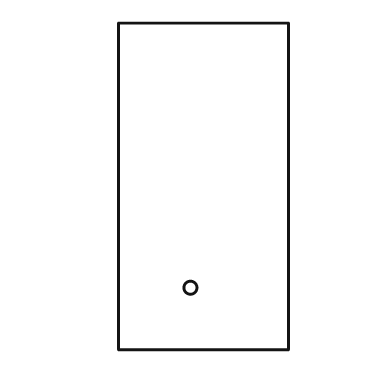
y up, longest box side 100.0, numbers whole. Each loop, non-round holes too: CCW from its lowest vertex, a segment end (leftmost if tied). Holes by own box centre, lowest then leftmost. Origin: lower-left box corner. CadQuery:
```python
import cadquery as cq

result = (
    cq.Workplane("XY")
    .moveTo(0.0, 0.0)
    .lineTo(52.0, 0.0)
    .lineTo(52.0, 100.0)
    .lineTo(0.0, 100.0)
    .close()
    .moveTo(22.0, 19.0)
    .circle(2.0)
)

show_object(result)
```